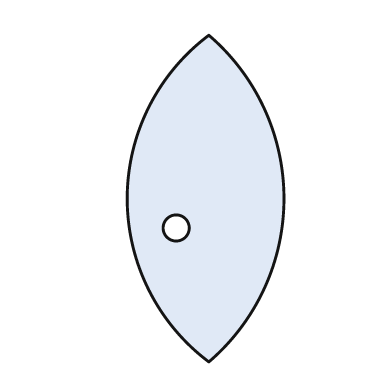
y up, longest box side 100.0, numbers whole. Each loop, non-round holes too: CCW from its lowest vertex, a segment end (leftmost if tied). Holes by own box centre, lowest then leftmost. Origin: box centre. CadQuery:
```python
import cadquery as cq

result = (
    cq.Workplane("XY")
    .moveTo(1.0, -50.0)
    .threePointArc((24.0, 0.0), (1.0, 50.0))
    .threePointArc((-24.0, 0.0), (1.0, -50.0))
    .close()
    .moveTo(-9.0, -9.0)
    .circle(4.0)
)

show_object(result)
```